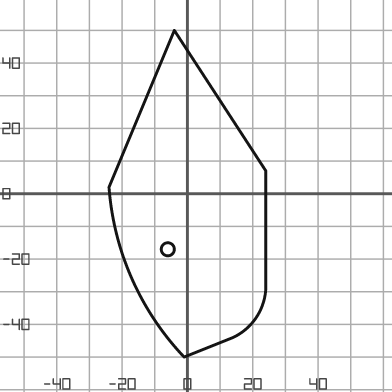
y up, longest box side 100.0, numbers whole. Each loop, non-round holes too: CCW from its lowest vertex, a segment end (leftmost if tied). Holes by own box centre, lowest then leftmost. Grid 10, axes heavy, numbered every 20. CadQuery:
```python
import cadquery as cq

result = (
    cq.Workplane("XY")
    .moveTo(-1.0, -50.0)
    .lineTo(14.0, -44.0)
    .threePointArc((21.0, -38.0), (24.0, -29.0))
    .lineTo(24.0, 7.0)
    .lineTo(-4.0, 50.0)
    .lineTo(-24.0, 2.0)
    .threePointArc((-17.0, -26.0), (-1.0, -50.0))
    .close()
    .moveTo(-6.0, -17.0)
    .circle(2.0)
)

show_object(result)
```